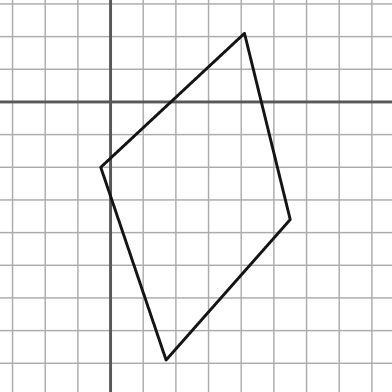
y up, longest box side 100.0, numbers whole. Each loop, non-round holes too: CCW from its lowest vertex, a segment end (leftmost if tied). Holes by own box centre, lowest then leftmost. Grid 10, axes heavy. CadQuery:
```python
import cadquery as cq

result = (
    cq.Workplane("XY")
    .moveTo(17.0, -79.0)
    .lineTo(55.0, -36.0)
    .lineTo(41.0, 21.0)
    .lineTo(-3.0, -20.0)
    .close()
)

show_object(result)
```